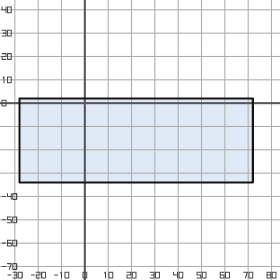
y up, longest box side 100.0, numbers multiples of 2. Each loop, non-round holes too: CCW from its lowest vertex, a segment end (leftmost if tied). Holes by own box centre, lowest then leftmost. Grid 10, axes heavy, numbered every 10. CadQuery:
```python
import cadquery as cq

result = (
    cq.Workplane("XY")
    .moveTo(-28.0, -34.0)
    .lineTo(72.0, -34.0)
    .lineTo(72.0, 2.0)
    .lineTo(-28.0, 2.0)
    .close()
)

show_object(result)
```